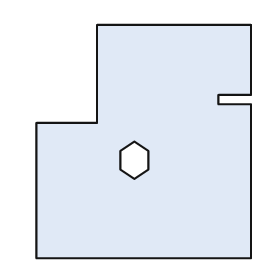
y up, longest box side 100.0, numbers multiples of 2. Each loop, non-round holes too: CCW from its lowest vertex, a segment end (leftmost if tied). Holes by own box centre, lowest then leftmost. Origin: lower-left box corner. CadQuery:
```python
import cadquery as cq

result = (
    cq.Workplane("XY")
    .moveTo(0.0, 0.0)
    .lineTo(92.0, 0.0)
    .lineTo(92.0, 66.0)
    .lineTo(78.0, 66.0)
    .lineTo(78.0, 70.0)
    .lineTo(92.0, 70.0)
    .lineTo(92.0, 100.0)
    .lineTo(26.0, 100.0)
    .lineTo(26.0, 58.0)
    .lineTo(0.0, 58.0)
    .close()
    .moveTo(42.0, 34.0)
    .lineTo(48.0, 38.0)
    .lineTo(48.0, 46.0)
    .lineTo(42.0, 50.0)
    .lineTo(36.0, 46.0)
    .lineTo(36.0, 38.0)
    .close()
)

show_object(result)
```